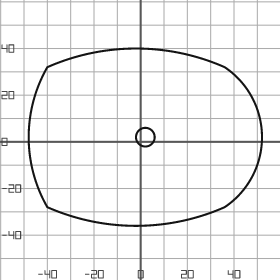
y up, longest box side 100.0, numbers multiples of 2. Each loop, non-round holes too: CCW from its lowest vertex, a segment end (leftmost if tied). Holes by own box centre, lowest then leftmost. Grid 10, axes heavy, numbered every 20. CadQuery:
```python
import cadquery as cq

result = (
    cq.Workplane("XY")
    .moveTo(-40.0, -28.0)
    .threePointArc((-2.0, -36.0), (36.0, -28.0))
    .threePointArc((52.0, 2.0), (36.0, 32.0))
    .threePointArc((-2.0, 40.0), (-40.0, 32.0))
    .threePointArc((-48.0, 2.0), (-40.0, -28.0))
    .close()
    .moveTo(2.0, 2.0)
    .circle(4.0)
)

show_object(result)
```